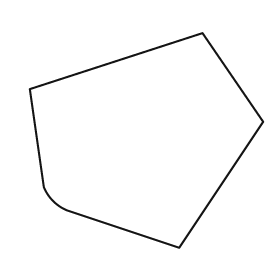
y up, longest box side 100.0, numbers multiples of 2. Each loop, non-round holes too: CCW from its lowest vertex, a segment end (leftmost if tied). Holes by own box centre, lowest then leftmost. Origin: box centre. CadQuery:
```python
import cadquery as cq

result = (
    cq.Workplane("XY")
    .moveTo(14.0, -46.0)
    .lineTo(50.0, 8.0)
    .lineTo(24.0, 46.0)
    .lineTo(-50.0, 22.0)
    .lineTo(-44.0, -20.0)
    .threePointArc((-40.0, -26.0), (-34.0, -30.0))
    .close()
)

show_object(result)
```